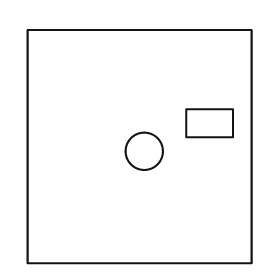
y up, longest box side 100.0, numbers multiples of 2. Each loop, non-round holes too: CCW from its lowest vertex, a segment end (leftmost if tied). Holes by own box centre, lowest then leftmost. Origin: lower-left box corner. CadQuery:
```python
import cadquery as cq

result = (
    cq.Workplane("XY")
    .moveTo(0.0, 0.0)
    .lineTo(96.0, 0.0)
    .lineTo(96.0, 100.0)
    .lineTo(0.0, 100.0)
    .close()
    .moveTo(50.0, 48.0)
    .circle(8.0)
    .moveTo(68.0, 54.0)
    .lineTo(88.0, 54.0)
    .lineTo(88.0, 66.0)
    .lineTo(68.0, 66.0)
    .close()
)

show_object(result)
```